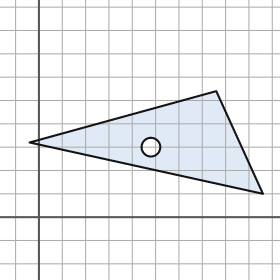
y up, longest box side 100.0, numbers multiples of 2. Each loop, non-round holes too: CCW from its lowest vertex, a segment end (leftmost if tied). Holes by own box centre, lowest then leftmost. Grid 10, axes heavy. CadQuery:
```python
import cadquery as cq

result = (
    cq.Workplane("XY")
    .moveTo(96.0, 10.0)
    .lineTo(76.0, 54.0)
    .lineTo(-4.0, 32.0)
    .close()
    .moveTo(48.0, 30.0)
    .circle(4.0)
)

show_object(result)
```